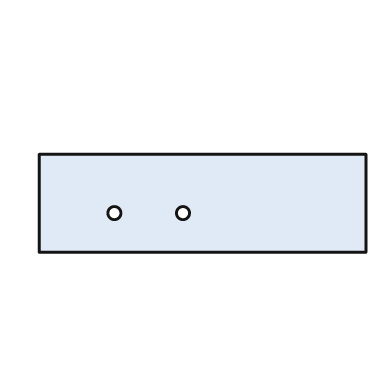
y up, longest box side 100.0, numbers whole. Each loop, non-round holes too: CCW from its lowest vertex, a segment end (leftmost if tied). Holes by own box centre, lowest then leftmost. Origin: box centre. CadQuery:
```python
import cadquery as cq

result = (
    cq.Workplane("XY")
    .moveTo(-50.0, -15.0)
    .lineTo(50.0, -15.0)
    .lineTo(50.0, 15.0)
    .lineTo(-50.0, 15.0)
    .close()
    .moveTo(-27.0, -3.0)
    .circle(2.0)
    .moveTo(-6.0, -3.0)
    .circle(2.0)
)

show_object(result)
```